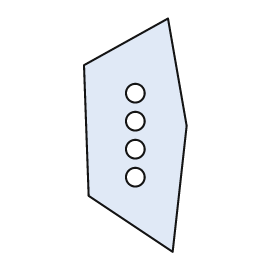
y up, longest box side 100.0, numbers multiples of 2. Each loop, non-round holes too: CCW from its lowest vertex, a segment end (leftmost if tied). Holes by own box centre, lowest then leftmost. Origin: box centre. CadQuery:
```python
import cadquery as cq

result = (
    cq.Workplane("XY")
    .moveTo(16.0, -50.0)
    .lineTo(22.0, 4.0)
    .lineTo(14.0, 50.0)
    .lineTo(-22.0, 30.0)
    .lineTo(-20.0, -26.0)
    .close()
    .moveTo(0.0, -18.0)
    .circle(4.0)
    .moveTo(0.0, -6.0)
    .circle(4.0)
    .moveTo(0.0, 6.0)
    .circle(4.0)
    .moveTo(0.0, 18.0)
    .circle(4.0)
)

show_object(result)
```